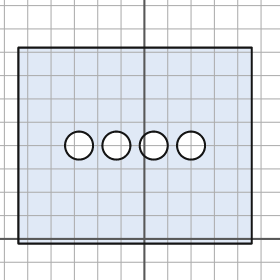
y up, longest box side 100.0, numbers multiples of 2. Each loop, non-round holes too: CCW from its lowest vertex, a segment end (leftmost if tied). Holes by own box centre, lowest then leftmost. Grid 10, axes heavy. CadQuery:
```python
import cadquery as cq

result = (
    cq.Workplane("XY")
    .moveTo(-54.0, -2.0)
    .lineTo(46.0, -2.0)
    .lineTo(46.0, 82.0)
    .lineTo(-54.0, 82.0)
    .close()
    .moveTo(-28.0, 40.0)
    .circle(6.0)
    .moveTo(-12.0, 40.0)
    .circle(6.0)
    .moveTo(4.0, 40.0)
    .circle(6.0)
    .moveTo(20.0, 40.0)
    .circle(6.0)
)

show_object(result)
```